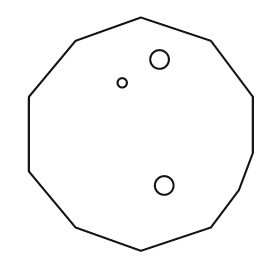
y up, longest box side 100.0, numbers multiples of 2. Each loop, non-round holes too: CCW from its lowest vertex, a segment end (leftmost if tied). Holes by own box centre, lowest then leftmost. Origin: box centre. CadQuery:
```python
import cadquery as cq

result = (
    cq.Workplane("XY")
    .moveTo(0.0, -50.0)
    .lineTo(30.0, -40.0)
    .lineTo(42.0, -24.0)
    .lineTo(48.0, -8.0)
    .lineTo(48.0, 16.0)
    .lineTo(30.0, 40.0)
    .lineTo(0.0, 50.0)
    .lineTo(-28.0, 40.0)
    .lineTo(-48.0, 16.0)
    .lineTo(-48.0, -16.0)
    .lineTo(-28.0, -40.0)
    .close()
    .moveTo(10.0, -22.0)
    .circle(4.0)
    .moveTo(-8.0, 22.0)
    .circle(2.0)
    .moveTo(8.0, 32.0)
    .circle(4.0)
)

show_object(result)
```